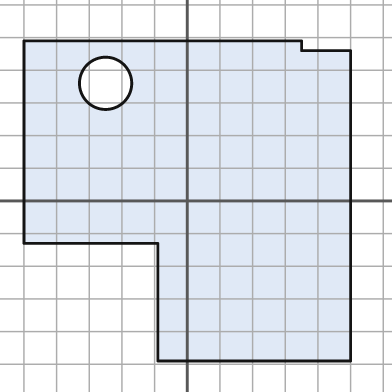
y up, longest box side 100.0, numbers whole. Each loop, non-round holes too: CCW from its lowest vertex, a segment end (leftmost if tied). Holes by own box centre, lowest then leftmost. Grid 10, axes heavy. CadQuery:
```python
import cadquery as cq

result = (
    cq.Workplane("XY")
    .moveTo(-9.0, -49.0)
    .lineTo(50.0, -49.0)
    .lineTo(50.0, 46.0)
    .lineTo(35.0, 46.0)
    .lineTo(35.0, 49.0)
    .lineTo(-50.0, 49.0)
    .lineTo(-50.0, -13.0)
    .lineTo(-9.0, -13.0)
    .close()
    .moveTo(-25.0, 36.0)
    .circle(8.0)
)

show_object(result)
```